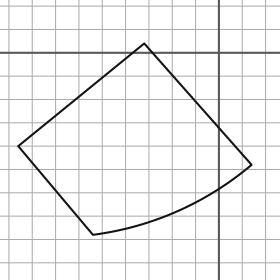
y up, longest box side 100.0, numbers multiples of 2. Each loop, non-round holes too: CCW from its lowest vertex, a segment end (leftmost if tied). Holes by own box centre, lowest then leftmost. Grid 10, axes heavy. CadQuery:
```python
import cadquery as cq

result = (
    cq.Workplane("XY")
    .moveTo(-54.0, -78.0)
    .threePointArc((-18.0, -68.0), (14.0, -48.0))
    .lineTo(-32.0, 4.0)
    .lineTo(-86.0, -40.0)
    .close()
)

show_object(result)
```